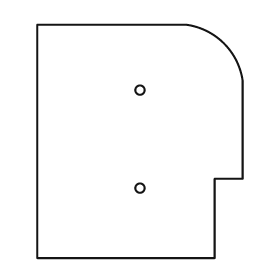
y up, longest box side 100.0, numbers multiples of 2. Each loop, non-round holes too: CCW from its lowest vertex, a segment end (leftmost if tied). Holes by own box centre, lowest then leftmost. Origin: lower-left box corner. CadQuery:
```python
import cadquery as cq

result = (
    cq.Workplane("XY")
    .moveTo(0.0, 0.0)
    .lineTo(76.0, 0.0)
    .lineTo(76.0, 34.0)
    .lineTo(88.0, 34.0)
    .lineTo(88.0, 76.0)
    .threePointArc((80.0, 92.0), (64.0, 100.0))
    .lineTo(0.0, 100.0)
    .close()
    .moveTo(44.0, 30.0)
    .circle(2.0)
    .moveTo(44.0, 72.0)
    .circle(2.0)
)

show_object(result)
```